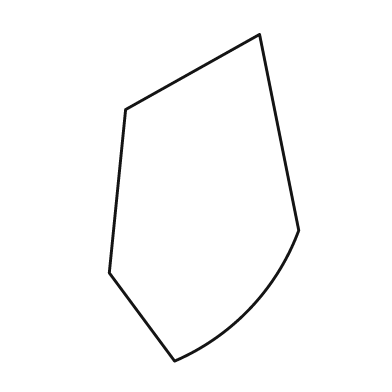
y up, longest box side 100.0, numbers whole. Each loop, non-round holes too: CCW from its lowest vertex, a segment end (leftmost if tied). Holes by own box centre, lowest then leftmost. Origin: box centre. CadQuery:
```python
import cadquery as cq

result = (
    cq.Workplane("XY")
    .moveTo(-9.0, -50.0)
    .threePointArc((14.0, -34.0), (29.0, -10.0))
    .lineTo(17.0, 50.0)
    .lineTo(-24.0, 27.0)
    .lineTo(-29.0, -23.0)
    .close()
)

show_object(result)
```